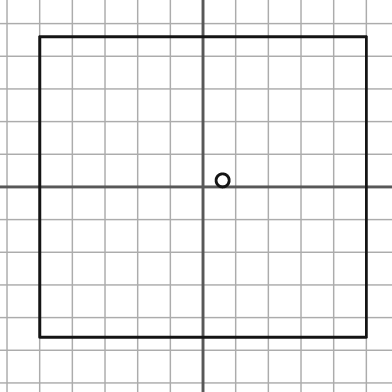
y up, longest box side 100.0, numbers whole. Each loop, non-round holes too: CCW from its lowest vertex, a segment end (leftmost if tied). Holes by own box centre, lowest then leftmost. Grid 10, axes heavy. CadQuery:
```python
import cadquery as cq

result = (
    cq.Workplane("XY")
    .moveTo(-50.0, -46.0)
    .lineTo(50.0, -46.0)
    .lineTo(50.0, 46.0)
    .lineTo(-50.0, 46.0)
    .close()
    .moveTo(6.0, 2.0)
    .circle(2.0)
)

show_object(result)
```